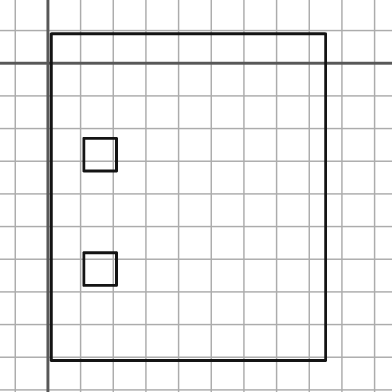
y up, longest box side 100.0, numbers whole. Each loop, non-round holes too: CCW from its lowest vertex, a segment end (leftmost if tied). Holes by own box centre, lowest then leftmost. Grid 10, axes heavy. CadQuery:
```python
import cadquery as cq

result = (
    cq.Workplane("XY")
    .moveTo(1.0, -91.0)
    .lineTo(85.0, -91.0)
    .lineTo(85.0, 9.0)
    .lineTo(1.0, 9.0)
    .close()
    .moveTo(11.0, -68.0)
    .lineTo(21.0, -68.0)
    .lineTo(21.0, -58.0)
    .lineTo(11.0, -58.0)
    .close()
    .moveTo(11.0, -33.0)
    .lineTo(21.0, -33.0)
    .lineTo(21.0, -23.0)
    .lineTo(11.0, -23.0)
    .close()
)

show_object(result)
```